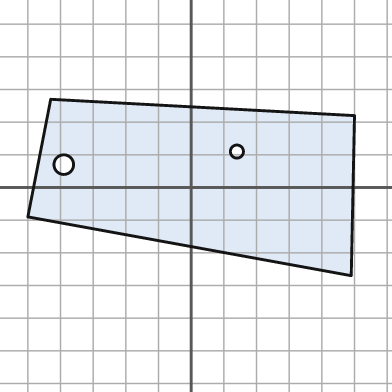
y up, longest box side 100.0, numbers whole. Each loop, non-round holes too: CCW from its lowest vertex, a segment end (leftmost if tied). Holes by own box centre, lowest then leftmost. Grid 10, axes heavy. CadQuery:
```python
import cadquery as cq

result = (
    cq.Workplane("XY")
    .moveTo(49.0, -27.0)
    .lineTo(50.0, 22.0)
    .lineTo(-43.0, 27.0)
    .lineTo(-50.0, -9.0)
    .close()
    .moveTo(-39.0, 7.0)
    .circle(3.0)
    .moveTo(14.0, 11.0)
    .circle(2.0)
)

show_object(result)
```